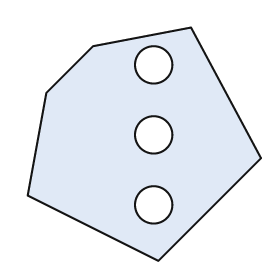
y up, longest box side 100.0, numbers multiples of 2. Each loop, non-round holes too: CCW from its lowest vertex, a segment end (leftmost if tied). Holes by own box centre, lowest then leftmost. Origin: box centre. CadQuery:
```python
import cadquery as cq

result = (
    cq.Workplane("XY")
    .moveTo(6.0, -50.0)
    .lineTo(50.0, -6.0)
    .lineTo(20.0, 50.0)
    .lineTo(-22.0, 42.0)
    .lineTo(-42.0, 22.0)
    .lineTo(-50.0, -22.0)
    .close()
    .moveTo(4.0, -26.0)
    .circle(8.0)
    .moveTo(4.0, 4.0)
    .circle(8.0)
    .moveTo(4.0, 34.0)
    .circle(8.0)
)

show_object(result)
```